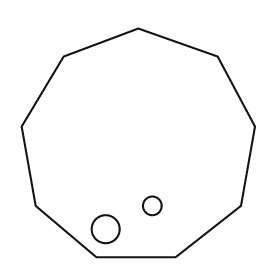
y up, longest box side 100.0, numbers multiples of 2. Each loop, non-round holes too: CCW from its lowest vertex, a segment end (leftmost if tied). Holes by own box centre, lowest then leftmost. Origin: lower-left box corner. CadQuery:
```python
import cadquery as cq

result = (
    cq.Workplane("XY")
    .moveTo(32.0, 0.0)
    .lineTo(66.0, 0.0)
    .lineTo(94.0, 22.0)
    .lineTo(100.0, 56.0)
    .lineTo(84.0, 86.0)
    .lineTo(50.0, 98.0)
    .lineTo(18.0, 86.0)
    .lineTo(0.0, 56.0)
    .lineTo(6.0, 22.0)
    .close()
    .moveTo(36.0, 12.0)
    .circle(6.0)
    .moveTo(56.0, 22.0)
    .circle(4.0)
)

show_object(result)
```